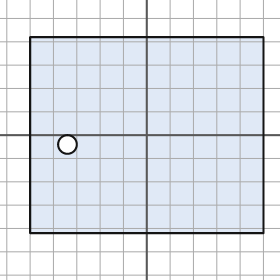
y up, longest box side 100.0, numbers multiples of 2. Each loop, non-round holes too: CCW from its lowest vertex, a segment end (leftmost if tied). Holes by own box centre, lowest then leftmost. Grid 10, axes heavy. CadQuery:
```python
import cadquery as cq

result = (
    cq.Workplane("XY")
    .moveTo(-50.0, -42.0)
    .lineTo(50.0, -42.0)
    .lineTo(50.0, 42.0)
    .lineTo(-50.0, 42.0)
    .close()
    .moveTo(-34.0, -4.0)
    .circle(4.0)
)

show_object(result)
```